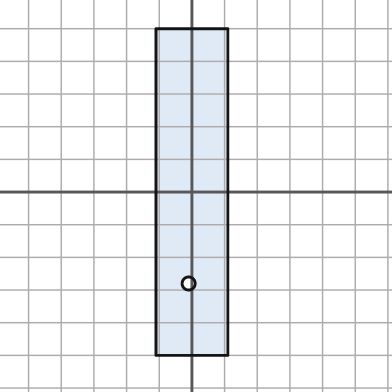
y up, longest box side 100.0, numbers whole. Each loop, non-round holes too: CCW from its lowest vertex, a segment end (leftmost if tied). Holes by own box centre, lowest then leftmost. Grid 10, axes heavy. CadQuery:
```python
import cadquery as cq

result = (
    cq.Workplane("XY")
    .moveTo(-11.0, -50.0)
    .lineTo(11.0, -50.0)
    .lineTo(11.0, 50.0)
    .lineTo(-11.0, 50.0)
    .close()
    .moveTo(-1.0, -28.0)
    .circle(2.0)
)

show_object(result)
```